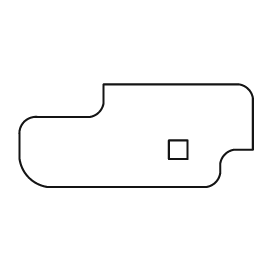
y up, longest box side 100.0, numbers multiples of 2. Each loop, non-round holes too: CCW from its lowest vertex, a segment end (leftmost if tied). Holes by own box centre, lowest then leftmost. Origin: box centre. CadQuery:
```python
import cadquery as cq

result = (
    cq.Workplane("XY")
    .moveTo(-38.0, -22.0)
    .lineTo(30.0, -22.0)
    .threePointArc((34.0, -20.0), (36.0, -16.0))
    .lineTo(36.0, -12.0)
    .threePointArc((38.0, -8.0), (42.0, -6.0))
    .lineTo(50.0, -6.0)
    .lineTo(50.0, 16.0)
    .threePointArc((48.0, 20.0), (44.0, 22.0))
    .lineTo(-14.0, 22.0)
    .lineTo(-14.0, 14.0)
    .threePointArc((-16.0, 10.0), (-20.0, 8.0))
    .lineTo(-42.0, 8.0)
    .threePointArc((-48.0, 6.0), (-50.0, 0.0))
    .lineTo(-50.0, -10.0)
    .threePointArc((-46.0, -18.0), (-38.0, -22.0))
    .close()
    .moveTo(14.0, -10.0)
    .lineTo(22.0, -10.0)
    .lineTo(22.0, -2.0)
    .lineTo(14.0, -2.0)
    .close()
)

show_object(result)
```